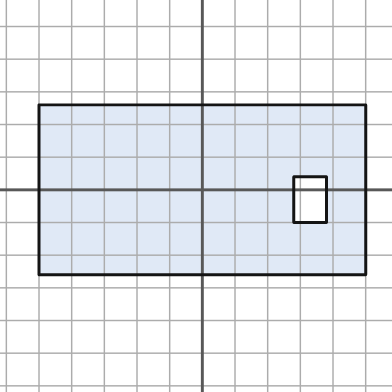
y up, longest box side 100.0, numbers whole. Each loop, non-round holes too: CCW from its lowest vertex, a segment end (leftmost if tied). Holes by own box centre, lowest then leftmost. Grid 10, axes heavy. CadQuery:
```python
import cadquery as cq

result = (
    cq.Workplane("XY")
    .moveTo(-50.0, -26.0)
    .lineTo(50.0, -26.0)
    .lineTo(50.0, 26.0)
    .lineTo(-50.0, 26.0)
    .close()
    .moveTo(28.0, -10.0)
    .lineTo(38.0, -10.0)
    .lineTo(38.0, 4.0)
    .lineTo(28.0, 4.0)
    .close()
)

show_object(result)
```